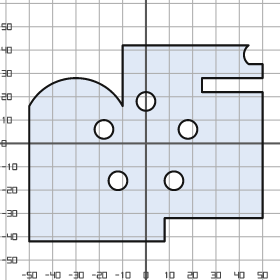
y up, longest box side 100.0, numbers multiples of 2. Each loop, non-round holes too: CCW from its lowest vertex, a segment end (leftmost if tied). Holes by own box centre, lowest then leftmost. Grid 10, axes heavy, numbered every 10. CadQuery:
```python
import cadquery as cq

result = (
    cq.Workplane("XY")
    .moveTo(-50.0, -42.0)
    .lineTo(8.0, -42.0)
    .lineTo(8.0, -32.0)
    .lineTo(50.0, -32.0)
    .lineTo(50.0, 22.0)
    .lineTo(24.0, 22.0)
    .lineTo(24.0, 28.0)
    .lineTo(50.0, 28.0)
    .lineTo(50.0, 34.0)
    .lineTo(44.0, 34.0)
    .threePointArc((42.0, 38.0), (44.0, 42.0))
    .lineTo(-10.0, 42.0)
    .lineTo(-10.0, 16.0)
    .threePointArc((-30.0, 28.0), (-50.0, 16.0))
    .close()
    .moveTo(-12.0, -16.0)
    .circle(4.0)
    .moveTo(12.0, -16.0)
    .circle(4.0)
    .moveTo(-18.0, 6.0)
    .circle(4.0)
    .moveTo(18.0, 6.0)
    .circle(4.0)
    .moveTo(0.0, 18.0)
    .circle(4.0)
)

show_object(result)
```